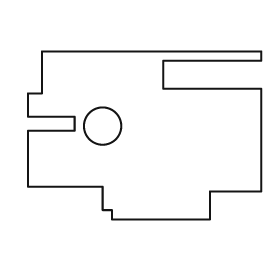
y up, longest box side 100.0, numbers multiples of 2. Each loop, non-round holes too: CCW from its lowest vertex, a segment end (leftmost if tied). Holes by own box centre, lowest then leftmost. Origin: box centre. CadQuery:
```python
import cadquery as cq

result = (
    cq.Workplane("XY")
    .moveTo(-14.0, -36.0)
    .lineTo(28.0, -36.0)
    .lineTo(28.0, -24.0)
    .lineTo(50.0, -24.0)
    .lineTo(50.0, 20.0)
    .lineTo(8.0, 20.0)
    .lineTo(8.0, 32.0)
    .lineTo(50.0, 32.0)
    .lineTo(50.0, 36.0)
    .lineTo(-44.0, 36.0)
    .lineTo(-44.0, 18.0)
    .lineTo(-50.0, 18.0)
    .lineTo(-50.0, 8.0)
    .lineTo(-30.0, 8.0)
    .lineTo(-30.0, 2.0)
    .lineTo(-50.0, 2.0)
    .lineTo(-50.0, -22.0)
    .lineTo(-18.0, -22.0)
    .lineTo(-18.0, -32.0)
    .lineTo(-14.0, -32.0)
    .close()
    .moveTo(-18.0, 4.0)
    .circle(8.0)
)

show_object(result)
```